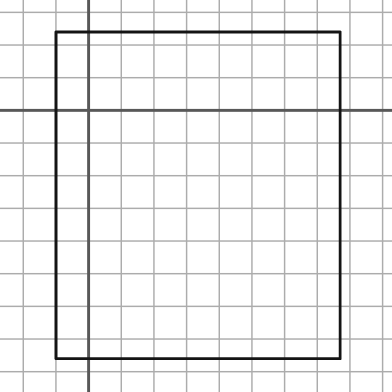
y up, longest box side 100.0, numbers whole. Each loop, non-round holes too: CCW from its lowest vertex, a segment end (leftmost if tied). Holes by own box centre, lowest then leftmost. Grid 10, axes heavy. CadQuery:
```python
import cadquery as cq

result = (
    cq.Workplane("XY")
    .moveTo(-10.0, -76.0)
    .lineTo(77.0, -76.0)
    .lineTo(77.0, 24.0)
    .lineTo(-10.0, 24.0)
    .close()
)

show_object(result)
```